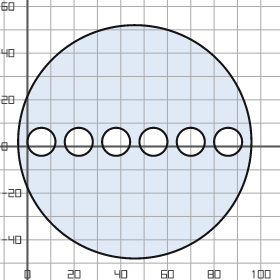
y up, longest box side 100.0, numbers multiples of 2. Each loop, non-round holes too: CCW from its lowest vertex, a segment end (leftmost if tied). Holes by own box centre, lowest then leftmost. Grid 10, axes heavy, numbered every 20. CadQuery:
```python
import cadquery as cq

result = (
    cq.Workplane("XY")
    .moveTo(46.0, 2.0)
    .circle(50.0)
    .moveTo(6.0, 2.0)
    .circle(6.0)
    .moveTo(22.0, 2.0)
    .circle(6.0)
    .moveTo(38.0, 2.0)
    .circle(6.0)
    .moveTo(54.0, 2.0)
    .circle(6.0)
    .moveTo(70.0, 2.0)
    .circle(6.0)
    .moveTo(86.0, 2.0)
    .circle(6.0)
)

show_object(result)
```